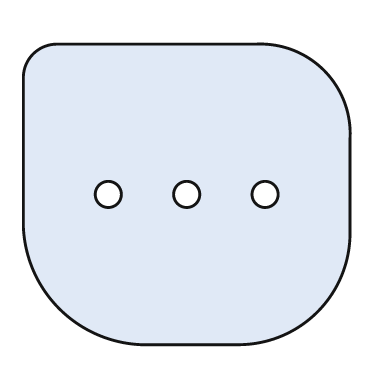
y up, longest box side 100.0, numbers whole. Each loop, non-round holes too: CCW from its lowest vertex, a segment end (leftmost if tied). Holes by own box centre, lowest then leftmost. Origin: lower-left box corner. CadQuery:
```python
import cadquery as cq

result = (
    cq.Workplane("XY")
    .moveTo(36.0, 0.0)
    .lineTo(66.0, 0.0)
    .threePointArc((90.0, 10.0), (100.0, 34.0))
    .lineTo(100.0, 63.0)
    .threePointArc((92.0, 84.0), (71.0, 92.0))
    .lineTo(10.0, 92.0)
    .threePointArc((3.0, 89.0), (0.0, 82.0))
    .lineTo(0.0, 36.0)
    .threePointArc((11.0, 11.0), (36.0, 0.0))
    .close()
    .moveTo(26.0, 46.0)
    .circle(4.0)
    .moveTo(50.0, 46.0)
    .circle(4.0)
    .moveTo(74.0, 46.0)
    .circle(4.0)
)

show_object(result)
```